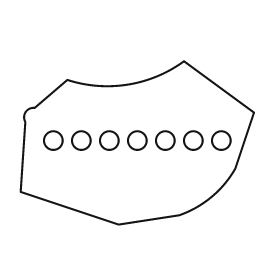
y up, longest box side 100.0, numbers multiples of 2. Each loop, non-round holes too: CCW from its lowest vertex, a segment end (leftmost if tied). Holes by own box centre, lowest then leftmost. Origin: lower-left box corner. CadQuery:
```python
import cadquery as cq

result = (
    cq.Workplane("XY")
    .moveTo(42.0, 0.0)
    .lineTo(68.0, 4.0)
    .threePointArc((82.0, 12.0), (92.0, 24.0))
    .lineTo(100.0, 48.0)
    .lineTo(70.0, 70.0)
    .threePointArc((46.0, 60.0), (20.0, 62.0))
    .lineTo(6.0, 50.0)
    .threePointArc((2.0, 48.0), (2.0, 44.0))
    .lineTo(0.0, 14.0)
    .close()
    .moveTo(14.0, 36.0)
    .circle(4.0)
    .moveTo(26.0, 36.0)
    .circle(4.0)
    .moveTo(38.0, 36.0)
    .circle(4.0)
    .moveTo(50.0, 36.0)
    .circle(4.0)
    .moveTo(62.0, 36.0)
    .circle(4.0)
    .moveTo(74.0, 36.0)
    .circle(4.0)
    .moveTo(86.0, 36.0)
    .circle(4.0)
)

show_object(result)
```